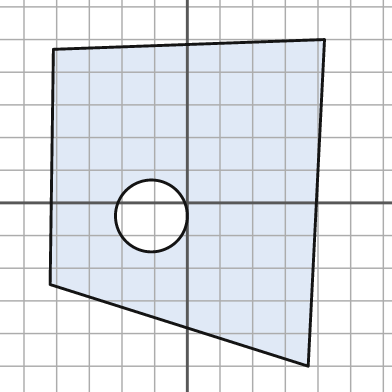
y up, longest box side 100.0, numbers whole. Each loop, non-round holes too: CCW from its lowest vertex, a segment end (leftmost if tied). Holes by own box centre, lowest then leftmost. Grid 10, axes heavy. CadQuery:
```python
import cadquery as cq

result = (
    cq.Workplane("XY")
    .moveTo(37.0, -50.0)
    .lineTo(42.0, 50.0)
    .lineTo(-41.0, 47.0)
    .lineTo(-42.0, -25.0)
    .close()
    .moveTo(-11.0, -4.0)
    .circle(11.0)
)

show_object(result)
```